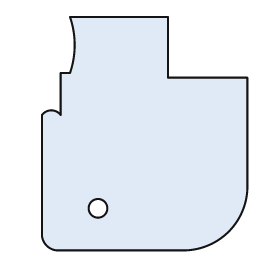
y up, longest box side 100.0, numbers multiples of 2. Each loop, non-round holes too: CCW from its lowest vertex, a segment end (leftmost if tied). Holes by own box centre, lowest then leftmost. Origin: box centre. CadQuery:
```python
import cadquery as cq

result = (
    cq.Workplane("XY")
    .moveTo(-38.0, -50.0)
    .lineTo(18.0, -50.0)
    .threePointArc((36.0, -42.0), (44.0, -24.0))
    .lineTo(44.0, 24.0)
    .lineTo(10.0, 24.0)
    .lineTo(10.0, 50.0)
    .lineTo(-32.0, 50.0)
    .threePointArc((-30.0, 38.0), (-32.0, 26.0))
    .lineTo(-36.0, 26.0)
    .lineTo(-36.0, 8.0)
    .threePointArc((-40.0, 10.0), (-44.0, 8.0))
    .lineTo(-44.0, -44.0)
    .threePointArc((-42.0, -48.0), (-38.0, -50.0))
    .close()
    .moveTo(-20.0, -32.0)
    .circle(4.0)
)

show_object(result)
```